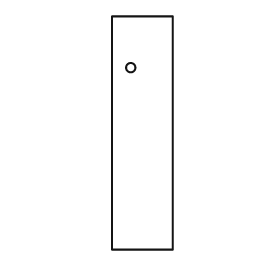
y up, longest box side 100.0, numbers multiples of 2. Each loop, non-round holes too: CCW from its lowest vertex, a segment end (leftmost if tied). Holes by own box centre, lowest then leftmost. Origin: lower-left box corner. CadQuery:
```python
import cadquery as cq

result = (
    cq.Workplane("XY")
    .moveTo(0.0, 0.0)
    .lineTo(26.0, 0.0)
    .lineTo(26.0, 100.0)
    .lineTo(0.0, 100.0)
    .close()
    .moveTo(8.0, 78.0)
    .circle(2.0)
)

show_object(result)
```